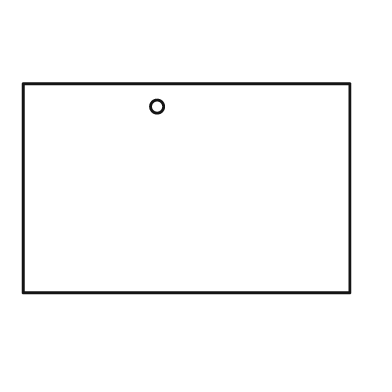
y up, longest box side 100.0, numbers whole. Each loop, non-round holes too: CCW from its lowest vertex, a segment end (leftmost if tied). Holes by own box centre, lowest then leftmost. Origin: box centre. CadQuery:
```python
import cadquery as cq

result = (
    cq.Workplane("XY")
    .moveTo(-50.0, -32.0)
    .lineTo(50.0, -32.0)
    .lineTo(50.0, 32.0)
    .lineTo(-50.0, 32.0)
    .close()
    .moveTo(-9.0, 25.0)
    .circle(2.0)
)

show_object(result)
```